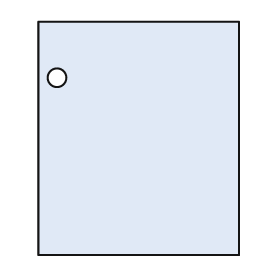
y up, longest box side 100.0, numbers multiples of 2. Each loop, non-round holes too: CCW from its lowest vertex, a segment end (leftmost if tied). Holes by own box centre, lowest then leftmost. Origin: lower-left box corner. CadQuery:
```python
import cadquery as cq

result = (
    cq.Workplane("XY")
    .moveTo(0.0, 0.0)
    .lineTo(86.0, 0.0)
    .lineTo(86.0, 100.0)
    .lineTo(0.0, 100.0)
    .close()
    .moveTo(8.0, 76.0)
    .circle(4.0)
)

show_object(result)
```